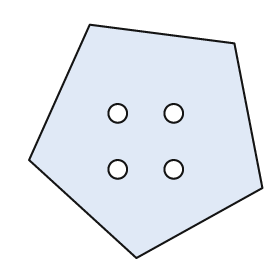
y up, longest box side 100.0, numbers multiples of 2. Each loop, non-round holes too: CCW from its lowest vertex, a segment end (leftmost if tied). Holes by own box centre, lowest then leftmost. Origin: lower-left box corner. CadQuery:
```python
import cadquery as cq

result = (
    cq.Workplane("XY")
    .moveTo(46.0, 0.0)
    .lineTo(100.0, 30.0)
    .lineTo(88.0, 92.0)
    .lineTo(26.0, 100.0)
    .lineTo(0.0, 42.0)
    .close()
    .moveTo(38.0, 38.0)
    .circle(4.0)
    .moveTo(62.0, 38.0)
    .circle(4.0)
    .moveTo(38.0, 62.0)
    .circle(4.0)
    .moveTo(62.0, 62.0)
    .circle(4.0)
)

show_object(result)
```